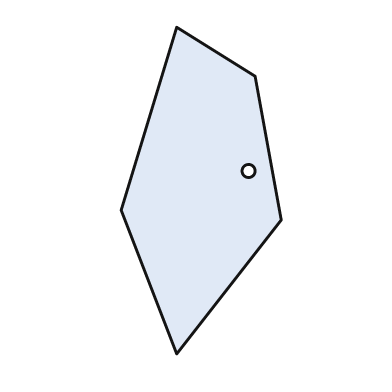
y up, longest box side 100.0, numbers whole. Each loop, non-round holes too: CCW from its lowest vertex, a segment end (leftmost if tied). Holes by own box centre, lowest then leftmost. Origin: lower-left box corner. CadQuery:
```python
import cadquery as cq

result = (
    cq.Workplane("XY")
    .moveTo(17.0, 0.0)
    .lineTo(49.0, 41.0)
    .lineTo(41.0, 85.0)
    .lineTo(17.0, 100.0)
    .lineTo(0.0, 44.0)
    .close()
    .moveTo(39.0, 56.0)
    .circle(2.0)
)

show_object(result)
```